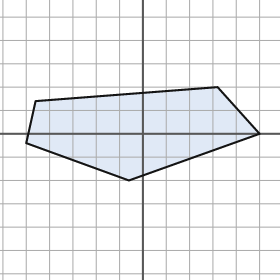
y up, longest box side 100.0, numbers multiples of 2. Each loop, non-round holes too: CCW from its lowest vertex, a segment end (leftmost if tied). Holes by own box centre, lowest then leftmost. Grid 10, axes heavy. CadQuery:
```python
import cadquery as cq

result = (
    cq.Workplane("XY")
    .moveTo(-6.0, -20.0)
    .lineTo(50.0, 0.0)
    .lineTo(32.0, 20.0)
    .lineTo(-46.0, 14.0)
    .lineTo(-50.0, -4.0)
    .close()
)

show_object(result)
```